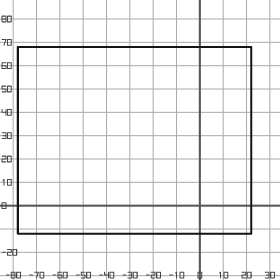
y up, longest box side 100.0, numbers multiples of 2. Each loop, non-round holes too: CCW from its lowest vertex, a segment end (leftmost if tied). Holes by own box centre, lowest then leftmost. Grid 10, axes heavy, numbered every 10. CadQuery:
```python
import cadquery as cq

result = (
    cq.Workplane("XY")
    .moveTo(-78.0, -12.0)
    .lineTo(22.0, -12.0)
    .lineTo(22.0, 68.0)
    .lineTo(-78.0, 68.0)
    .close()
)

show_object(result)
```